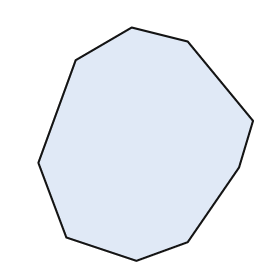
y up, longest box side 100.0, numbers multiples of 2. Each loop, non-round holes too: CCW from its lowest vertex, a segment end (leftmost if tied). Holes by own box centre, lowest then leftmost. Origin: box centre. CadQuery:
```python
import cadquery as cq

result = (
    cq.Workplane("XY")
    .moveTo(-4.0, -50.0)
    .lineTo(18.0, -42.0)
    .lineTo(40.0, -10.0)
    .lineTo(46.0, 10.0)
    .lineTo(18.0, 44.0)
    .lineTo(-6.0, 50.0)
    .lineTo(-30.0, 36.0)
    .lineTo(-46.0, -8.0)
    .lineTo(-34.0, -40.0)
    .close()
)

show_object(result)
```